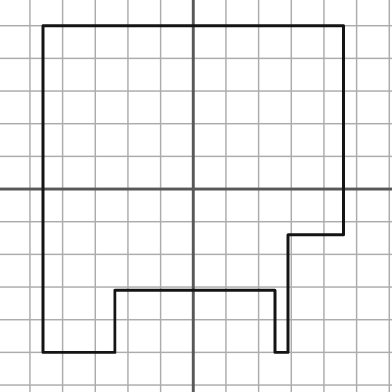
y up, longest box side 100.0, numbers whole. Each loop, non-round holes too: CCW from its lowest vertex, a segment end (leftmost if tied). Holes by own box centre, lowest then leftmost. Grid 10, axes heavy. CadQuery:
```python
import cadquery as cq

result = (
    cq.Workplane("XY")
    .moveTo(-46.0, -50.0)
    .lineTo(-24.0, -50.0)
    .lineTo(-24.0, -31.0)
    .lineTo(25.0, -31.0)
    .lineTo(25.0, -50.0)
    .lineTo(29.0, -50.0)
    .lineTo(29.0, -14.0)
    .lineTo(46.0, -14.0)
    .lineTo(46.0, 50.0)
    .lineTo(-46.0, 50.0)
    .close()
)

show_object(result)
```